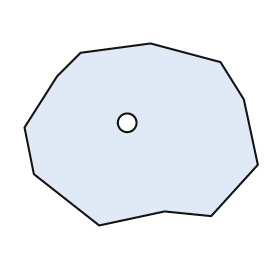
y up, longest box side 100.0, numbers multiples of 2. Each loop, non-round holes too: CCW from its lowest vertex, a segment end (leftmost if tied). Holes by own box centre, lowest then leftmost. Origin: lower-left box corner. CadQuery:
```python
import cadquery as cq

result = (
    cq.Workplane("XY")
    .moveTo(32.0, 0.0)
    .lineTo(60.0, 6.0)
    .lineTo(80.0, 4.0)
    .lineTo(100.0, 26.0)
    .lineTo(94.0, 54.0)
    .lineTo(84.0, 70.0)
    .lineTo(54.0, 78.0)
    .lineTo(24.0, 74.0)
    .lineTo(14.0, 64.0)
    .lineTo(0.0, 42.0)
    .lineTo(4.0, 22.0)
    .close()
    .moveTo(44.0, 44.0)
    .circle(4.0)
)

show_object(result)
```